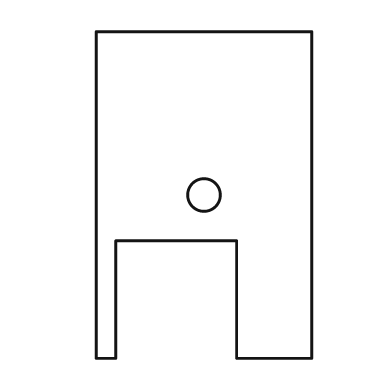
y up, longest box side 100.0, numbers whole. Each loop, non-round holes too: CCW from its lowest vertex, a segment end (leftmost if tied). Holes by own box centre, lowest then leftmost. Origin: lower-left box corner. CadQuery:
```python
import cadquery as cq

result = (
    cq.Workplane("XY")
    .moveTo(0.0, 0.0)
    .lineTo(6.0, 0.0)
    .lineTo(6.0, 36.0)
    .lineTo(43.0, 36.0)
    .lineTo(43.0, 0.0)
    .lineTo(66.0, 0.0)
    .lineTo(66.0, 100.0)
    .lineTo(0.0, 100.0)
    .close()
    .moveTo(33.0, 50.0)
    .circle(5.0)
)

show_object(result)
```